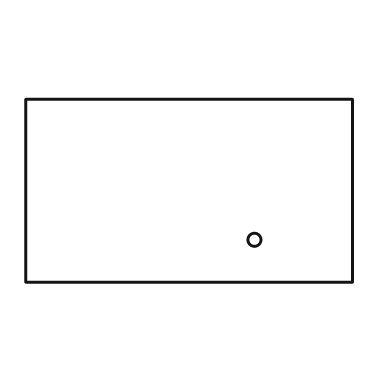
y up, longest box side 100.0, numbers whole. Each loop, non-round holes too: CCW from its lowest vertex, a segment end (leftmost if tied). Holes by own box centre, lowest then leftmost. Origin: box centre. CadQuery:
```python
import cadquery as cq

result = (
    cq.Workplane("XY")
    .moveTo(-50.0, -28.0)
    .lineTo(50.0, -28.0)
    .lineTo(50.0, 28.0)
    .lineTo(-50.0, 28.0)
    .close()
    .moveTo(20.0, -15.0)
    .circle(2.0)
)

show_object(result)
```